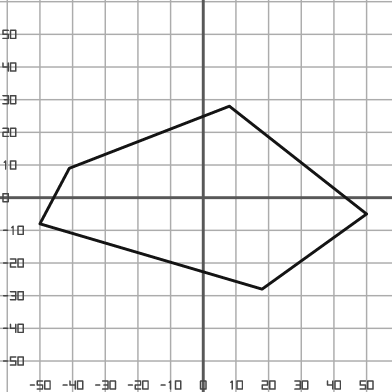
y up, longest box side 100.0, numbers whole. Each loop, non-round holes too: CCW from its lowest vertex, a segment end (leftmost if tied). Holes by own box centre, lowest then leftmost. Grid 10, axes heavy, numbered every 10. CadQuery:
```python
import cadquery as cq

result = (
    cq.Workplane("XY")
    .moveTo(18.0, -28.0)
    .lineTo(50.0, -5.0)
    .lineTo(8.0, 28.0)
    .lineTo(-41.0, 9.0)
    .lineTo(-50.0, -8.0)
    .close()
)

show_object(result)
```